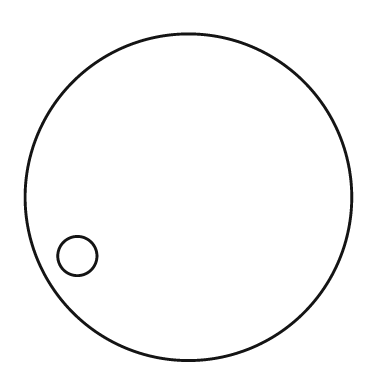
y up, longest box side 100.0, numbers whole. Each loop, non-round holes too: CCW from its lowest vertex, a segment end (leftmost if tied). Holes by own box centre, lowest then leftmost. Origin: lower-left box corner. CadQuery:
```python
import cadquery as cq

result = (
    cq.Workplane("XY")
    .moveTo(50.0, 50.0)
    .circle(50.0)
    .moveTo(16.0, 32.0)
    .circle(6.0)
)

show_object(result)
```